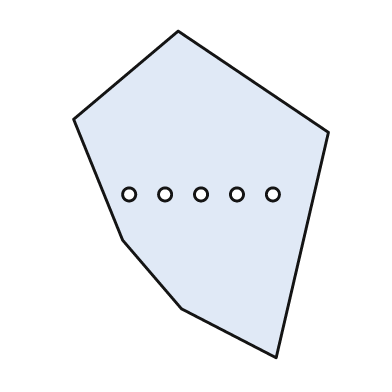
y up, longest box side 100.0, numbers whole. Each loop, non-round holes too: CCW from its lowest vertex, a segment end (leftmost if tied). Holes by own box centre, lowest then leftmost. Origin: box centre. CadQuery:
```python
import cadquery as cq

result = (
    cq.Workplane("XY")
    .moveTo(23.0, -50.0)
    .lineTo(39.0, 19.0)
    .lineTo(-7.0, 50.0)
    .lineTo(-39.0, 23.0)
    .lineTo(-24.0, -14.0)
    .lineTo(-6.0, -35.0)
    .close()
    .moveTo(-22.0, 0.0)
    .circle(2.0)
    .moveTo(-11.0, 0.0)
    .circle(2.0)
    .moveTo(0.0, 0.0)
    .circle(2.0)
    .moveTo(11.0, 0.0)
    .circle(2.0)
    .moveTo(22.0, 0.0)
    .circle(2.0)
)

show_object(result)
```